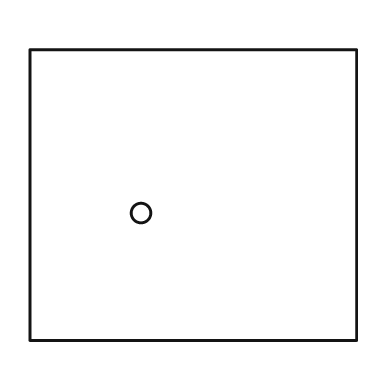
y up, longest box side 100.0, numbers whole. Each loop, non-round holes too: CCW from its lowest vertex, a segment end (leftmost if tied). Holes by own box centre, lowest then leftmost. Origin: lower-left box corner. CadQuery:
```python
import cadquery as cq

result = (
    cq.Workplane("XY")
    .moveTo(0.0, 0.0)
    .lineTo(100.0, 0.0)
    .lineTo(100.0, 89.0)
    .lineTo(0.0, 89.0)
    .close()
    .moveTo(34.0, 39.0)
    .circle(3.0)
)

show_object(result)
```